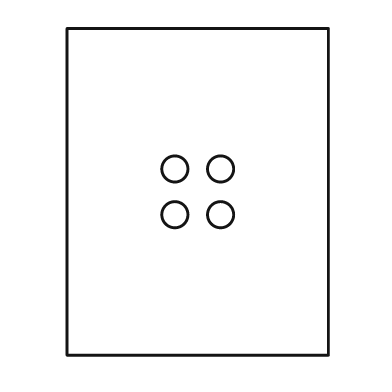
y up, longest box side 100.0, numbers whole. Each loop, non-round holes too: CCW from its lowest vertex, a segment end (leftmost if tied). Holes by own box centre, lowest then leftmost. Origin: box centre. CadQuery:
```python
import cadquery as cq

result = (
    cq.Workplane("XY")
    .moveTo(-40.0, -50.0)
    .lineTo(40.0, -50.0)
    .lineTo(40.0, 50.0)
    .lineTo(-40.0, 50.0)
    .close()
    .moveTo(-7.0, -7.0)
    .circle(4.0)
    .moveTo(7.0, -7.0)
    .circle(4.0)
    .moveTo(-7.0, 7.0)
    .circle(4.0)
    .moveTo(7.0, 7.0)
    .circle(4.0)
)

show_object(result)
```